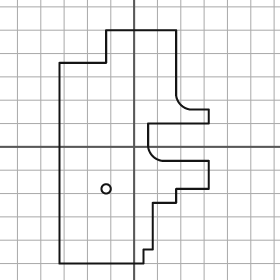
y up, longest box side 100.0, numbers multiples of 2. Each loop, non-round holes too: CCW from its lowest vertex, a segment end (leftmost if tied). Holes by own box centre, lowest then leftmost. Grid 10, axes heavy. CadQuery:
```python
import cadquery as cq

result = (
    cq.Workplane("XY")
    .moveTo(-32.0, -50.0)
    .lineTo(4.0, -50.0)
    .lineTo(4.0, -44.0)
    .lineTo(8.0, -44.0)
    .lineTo(8.0, -24.0)
    .lineTo(18.0, -24.0)
    .lineTo(18.0, -18.0)
    .lineTo(32.0, -18.0)
    .lineTo(32.0, -6.0)
    .lineTo(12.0, -6.0)
    .threePointArc((8.0, -4.0), (6.0, 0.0))
    .lineTo(6.0, 10.0)
    .lineTo(32.0, 10.0)
    .lineTo(32.0, 16.0)
    .lineTo(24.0, 16.0)
    .threePointArc((20.0, 18.0), (18.0, 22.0))
    .lineTo(18.0, 50.0)
    .lineTo(-12.0, 50.0)
    .lineTo(-12.0, 36.0)
    .lineTo(-32.0, 36.0)
    .close()
    .moveTo(-12.0, -18.0)
    .circle(2.0)
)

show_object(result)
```